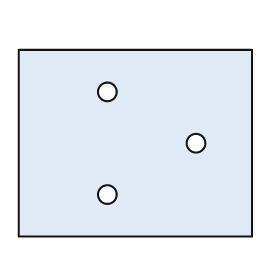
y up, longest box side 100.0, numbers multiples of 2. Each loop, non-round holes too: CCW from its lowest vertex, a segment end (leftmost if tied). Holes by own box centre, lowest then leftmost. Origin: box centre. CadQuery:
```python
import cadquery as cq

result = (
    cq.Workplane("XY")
    .moveTo(-50.0, -40.0)
    .lineTo(50.0, -40.0)
    .lineTo(50.0, 40.0)
    .lineTo(-50.0, 40.0)
    .close()
    .moveTo(-12.0, -22.0)
    .circle(4.0)
    .moveTo(26.0, 0.0)
    .circle(4.0)
    .moveTo(-12.0, 22.0)
    .circle(4.0)
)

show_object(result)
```